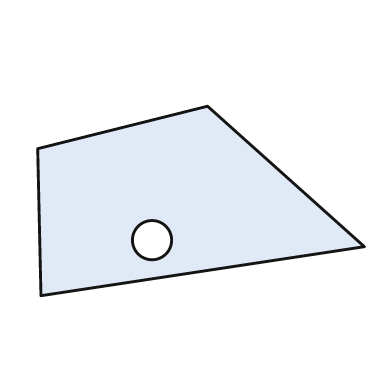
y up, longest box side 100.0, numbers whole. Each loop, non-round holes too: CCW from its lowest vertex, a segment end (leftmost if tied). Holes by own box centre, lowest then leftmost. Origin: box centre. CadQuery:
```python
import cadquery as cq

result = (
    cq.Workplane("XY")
    .moveTo(-49.0, -29.0)
    .lineTo(50.0, -14.0)
    .lineTo(2.0, 29.0)
    .lineTo(-50.0, 16.0)
    .close()
    .moveTo(-15.0, -12.0)
    .circle(6.0)
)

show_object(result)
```